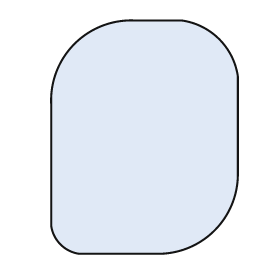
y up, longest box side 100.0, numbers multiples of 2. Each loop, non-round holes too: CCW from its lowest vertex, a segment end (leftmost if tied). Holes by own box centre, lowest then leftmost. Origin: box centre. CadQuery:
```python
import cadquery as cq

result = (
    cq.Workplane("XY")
    .moveTo(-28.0, -50.0)
    .lineTo(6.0, -50.0)
    .threePointArc((30.0, -40.0), (40.0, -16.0))
    .lineTo(40.0, 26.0)
    .threePointArc((32.0, 42.0), (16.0, 50.0))
    .lineTo(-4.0, 50.0)
    .threePointArc((-30.0, 40.0), (-40.0, 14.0))
    .lineTo(-40.0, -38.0)
    .threePointArc((-36.0, -46.0), (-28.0, -50.0))
    .close()
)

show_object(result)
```